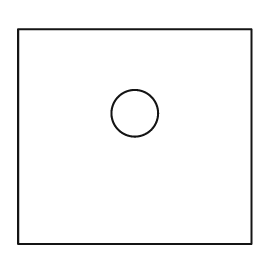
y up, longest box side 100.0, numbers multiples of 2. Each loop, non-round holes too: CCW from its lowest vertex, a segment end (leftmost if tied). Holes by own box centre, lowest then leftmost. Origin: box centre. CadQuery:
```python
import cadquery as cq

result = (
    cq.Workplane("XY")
    .moveTo(-50.0, -46.0)
    .lineTo(50.0, -46.0)
    .lineTo(50.0, 46.0)
    .lineTo(-50.0, 46.0)
    .close()
    .moveTo(0.0, 10.0)
    .circle(10.0)
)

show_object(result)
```